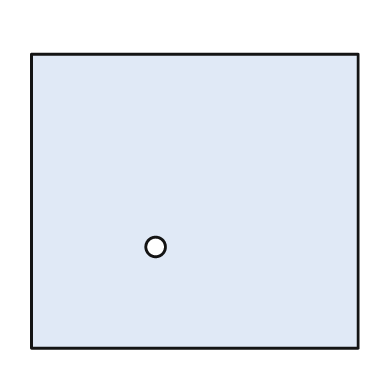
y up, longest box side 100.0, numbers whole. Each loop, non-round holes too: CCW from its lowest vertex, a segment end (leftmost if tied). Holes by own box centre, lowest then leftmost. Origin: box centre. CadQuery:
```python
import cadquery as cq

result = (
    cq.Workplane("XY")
    .moveTo(-50.0, -45.0)
    .lineTo(50.0, -45.0)
    .lineTo(50.0, 45.0)
    .lineTo(-50.0, 45.0)
    .close()
    .moveTo(-12.0, -14.0)
    .circle(3.0)
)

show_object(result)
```